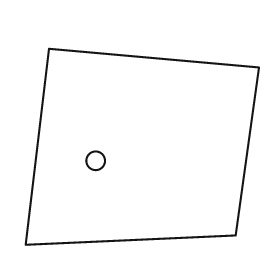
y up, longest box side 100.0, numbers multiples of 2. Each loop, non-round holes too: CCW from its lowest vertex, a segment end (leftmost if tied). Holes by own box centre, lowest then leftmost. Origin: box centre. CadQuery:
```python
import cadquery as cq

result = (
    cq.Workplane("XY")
    .moveTo(-50.0, -42.0)
    .lineTo(40.0, -38.0)
    .lineTo(50.0, 34.0)
    .lineTo(-40.0, 42.0)
    .close()
    .moveTo(-20.0, -6.0)
    .circle(4.0)
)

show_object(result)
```